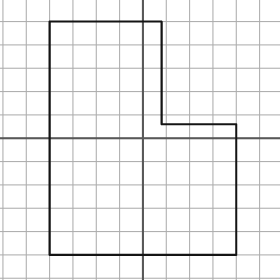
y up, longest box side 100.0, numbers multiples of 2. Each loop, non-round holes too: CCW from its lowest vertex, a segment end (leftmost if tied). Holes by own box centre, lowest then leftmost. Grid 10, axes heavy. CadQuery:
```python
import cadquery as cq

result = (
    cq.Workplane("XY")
    .moveTo(-40.0, -50.0)
    .lineTo(40.0, -50.0)
    .lineTo(40.0, 6.0)
    .lineTo(8.0, 6.0)
    .lineTo(8.0, 50.0)
    .lineTo(-40.0, 50.0)
    .close()
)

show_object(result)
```